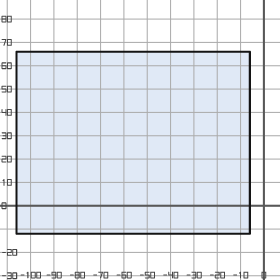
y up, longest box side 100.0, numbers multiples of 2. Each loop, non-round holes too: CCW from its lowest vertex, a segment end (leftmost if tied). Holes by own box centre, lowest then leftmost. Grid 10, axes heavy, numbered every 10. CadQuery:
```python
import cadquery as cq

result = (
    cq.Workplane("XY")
    .moveTo(-106.0, -12.0)
    .lineTo(-6.0, -12.0)
    .lineTo(-6.0, 66.0)
    .lineTo(-106.0, 66.0)
    .close()
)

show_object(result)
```